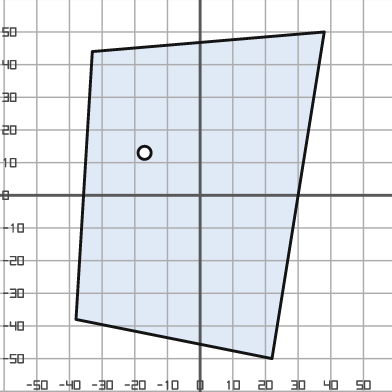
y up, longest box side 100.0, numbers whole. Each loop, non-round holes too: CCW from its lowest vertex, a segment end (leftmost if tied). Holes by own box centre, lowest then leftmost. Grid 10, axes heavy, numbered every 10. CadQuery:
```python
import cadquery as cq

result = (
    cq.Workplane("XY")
    .moveTo(22.0, -50.0)
    .lineTo(38.0, 50.0)
    .lineTo(-33.0, 44.0)
    .lineTo(-38.0, -38.0)
    .close()
    .moveTo(-17.0, 13.0)
    .circle(2.0)
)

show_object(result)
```